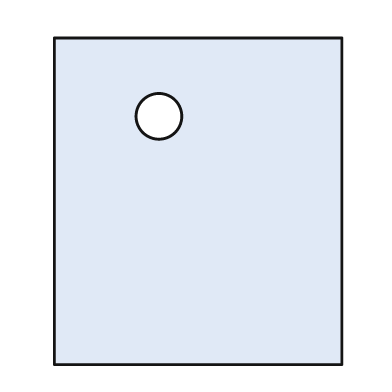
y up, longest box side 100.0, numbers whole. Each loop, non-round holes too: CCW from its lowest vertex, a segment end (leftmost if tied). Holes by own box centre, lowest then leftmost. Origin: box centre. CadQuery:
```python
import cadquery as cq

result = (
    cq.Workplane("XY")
    .moveTo(-44.0, -50.0)
    .lineTo(44.0, -50.0)
    .lineTo(44.0, 50.0)
    .lineTo(-44.0, 50.0)
    .close()
    .moveTo(-12.0, 26.0)
    .circle(7.0)
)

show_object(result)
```